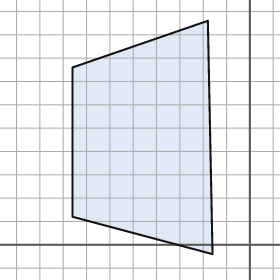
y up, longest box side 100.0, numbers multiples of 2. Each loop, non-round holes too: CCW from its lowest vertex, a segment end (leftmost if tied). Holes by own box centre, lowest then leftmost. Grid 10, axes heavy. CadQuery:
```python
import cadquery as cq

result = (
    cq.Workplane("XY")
    .moveTo(-16.0, -4.0)
    .lineTo(-18.0, 96.0)
    .lineTo(-76.0, 76.0)
    .lineTo(-76.0, 12.0)
    .close()
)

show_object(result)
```